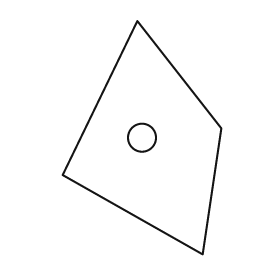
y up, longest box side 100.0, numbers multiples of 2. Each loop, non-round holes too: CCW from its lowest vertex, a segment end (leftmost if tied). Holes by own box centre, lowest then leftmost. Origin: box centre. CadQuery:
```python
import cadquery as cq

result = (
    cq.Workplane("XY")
    .moveTo(26.0, -50.0)
    .lineTo(34.0, 4.0)
    .lineTo(-2.0, 50.0)
    .lineTo(-34.0, -16.0)
    .close()
    .moveTo(0.0, 0.0)
    .circle(6.0)
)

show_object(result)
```